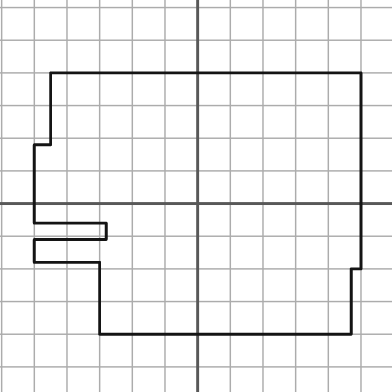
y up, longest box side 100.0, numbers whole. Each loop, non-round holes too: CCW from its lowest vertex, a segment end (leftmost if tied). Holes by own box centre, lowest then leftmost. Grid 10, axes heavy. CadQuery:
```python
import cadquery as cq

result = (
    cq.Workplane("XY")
    .moveTo(-30.0, -40.0)
    .lineTo(47.0, -40.0)
    .lineTo(47.0, -20.0)
    .lineTo(50.0, -20.0)
    .lineTo(50.0, 40.0)
    .lineTo(-45.0, 40.0)
    .lineTo(-45.0, 18.0)
    .lineTo(-50.0, 18.0)
    .lineTo(-50.0, -6.0)
    .lineTo(-28.0, -6.0)
    .lineTo(-28.0, -11.0)
    .lineTo(-50.0, -11.0)
    .lineTo(-50.0, -18.0)
    .lineTo(-30.0, -18.0)
    .close()
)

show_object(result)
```